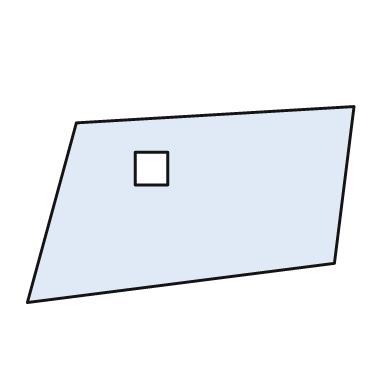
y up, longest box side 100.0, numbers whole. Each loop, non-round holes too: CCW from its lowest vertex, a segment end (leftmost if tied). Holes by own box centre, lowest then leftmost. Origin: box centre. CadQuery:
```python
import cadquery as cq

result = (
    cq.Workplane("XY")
    .moveTo(-50.0, -30.0)
    .lineTo(44.0, -18.0)
    .lineTo(50.0, 30.0)
    .lineTo(-35.0, 25.0)
    .close()
    .moveTo(-17.0, 6.0)
    .lineTo(-7.0, 6.0)
    .lineTo(-7.0, 16.0)
    .lineTo(-17.0, 16.0)
    .close()
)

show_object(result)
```